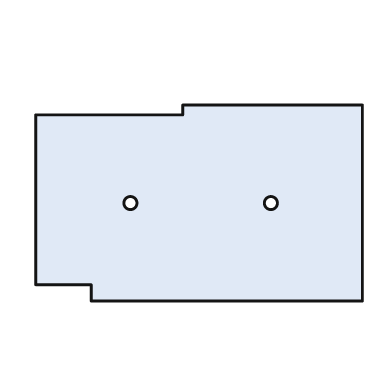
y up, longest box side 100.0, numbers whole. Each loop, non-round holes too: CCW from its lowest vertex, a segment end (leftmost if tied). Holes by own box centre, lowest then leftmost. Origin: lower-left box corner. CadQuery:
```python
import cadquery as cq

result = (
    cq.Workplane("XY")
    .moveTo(17.0, 0.0)
    .lineTo(100.0, 0.0)
    .lineTo(100.0, 60.0)
    .lineTo(45.0, 60.0)
    .lineTo(45.0, 57.0)
    .lineTo(0.0, 57.0)
    .lineTo(0.0, 5.0)
    .lineTo(17.0, 5.0)
    .close()
    .moveTo(29.0, 30.0)
    .circle(2.0)
    .moveTo(72.0, 30.0)
    .circle(2.0)
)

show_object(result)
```